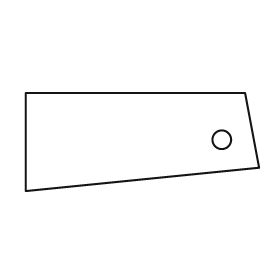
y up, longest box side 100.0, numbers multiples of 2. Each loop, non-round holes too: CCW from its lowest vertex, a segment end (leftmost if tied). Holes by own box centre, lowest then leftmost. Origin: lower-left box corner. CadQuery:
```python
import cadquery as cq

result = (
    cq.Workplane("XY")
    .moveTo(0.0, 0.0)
    .lineTo(100.0, 10.0)
    .lineTo(94.0, 42.0)
    .lineTo(0.0, 42.0)
    .close()
    .moveTo(84.0, 22.0)
    .circle(4.0)
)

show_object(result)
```